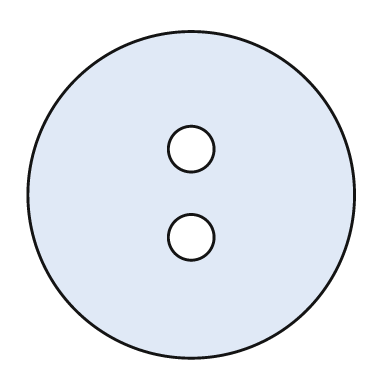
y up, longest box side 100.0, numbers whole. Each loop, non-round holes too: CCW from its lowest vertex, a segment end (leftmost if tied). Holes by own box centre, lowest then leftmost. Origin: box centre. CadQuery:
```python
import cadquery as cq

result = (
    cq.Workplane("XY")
    .moveTo(0.0, 0.0)
    .circle(50.0)
    .moveTo(0.0, -13.0)
    .circle(7.0)
    .moveTo(0.0, 14.0)
    .circle(7.0)
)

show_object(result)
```